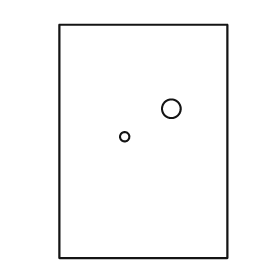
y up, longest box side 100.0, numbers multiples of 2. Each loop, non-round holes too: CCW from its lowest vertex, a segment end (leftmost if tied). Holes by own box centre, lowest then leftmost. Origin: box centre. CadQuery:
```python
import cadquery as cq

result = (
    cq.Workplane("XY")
    .moveTo(-36.0, -50.0)
    .lineTo(36.0, -50.0)
    .lineTo(36.0, 50.0)
    .lineTo(-36.0, 50.0)
    .close()
    .moveTo(-8.0, 2.0)
    .circle(2.0)
    .moveTo(12.0, 14.0)
    .circle(4.0)
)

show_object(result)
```